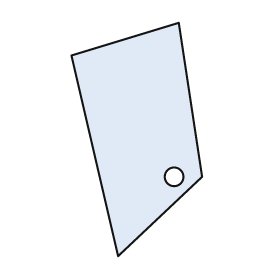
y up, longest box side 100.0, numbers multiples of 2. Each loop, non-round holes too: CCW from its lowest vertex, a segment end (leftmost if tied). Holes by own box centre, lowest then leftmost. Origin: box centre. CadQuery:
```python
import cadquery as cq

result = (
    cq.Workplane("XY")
    .moveTo(-8.0, -50.0)
    .lineTo(28.0, -16.0)
    .lineTo(18.0, 50.0)
    .lineTo(-28.0, 36.0)
    .close()
    .moveTo(16.0, -16.0)
    .circle(4.0)
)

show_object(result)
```